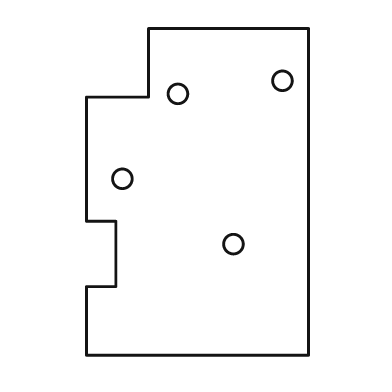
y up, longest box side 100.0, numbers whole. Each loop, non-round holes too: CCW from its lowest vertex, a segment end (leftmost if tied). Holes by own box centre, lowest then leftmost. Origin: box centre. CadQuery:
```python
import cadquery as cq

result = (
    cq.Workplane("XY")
    .moveTo(-34.0, -50.0)
    .lineTo(34.0, -50.0)
    .lineTo(34.0, 50.0)
    .lineTo(-15.0, 50.0)
    .lineTo(-15.0, 29.0)
    .lineTo(-34.0, 29.0)
    .lineTo(-34.0, -9.0)
    .lineTo(-25.0, -9.0)
    .lineTo(-25.0, -29.0)
    .lineTo(-34.0, -29.0)
    .close()
    .moveTo(11.0, -16.0)
    .circle(3.0)
    .moveTo(-23.0, 4.0)
    .circle(3.0)
    .moveTo(-6.0, 30.0)
    .circle(3.0)
    .moveTo(26.0, 34.0)
    .circle(3.0)
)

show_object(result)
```